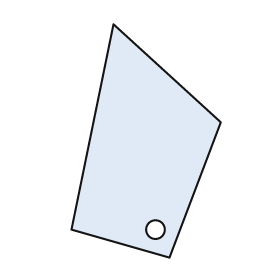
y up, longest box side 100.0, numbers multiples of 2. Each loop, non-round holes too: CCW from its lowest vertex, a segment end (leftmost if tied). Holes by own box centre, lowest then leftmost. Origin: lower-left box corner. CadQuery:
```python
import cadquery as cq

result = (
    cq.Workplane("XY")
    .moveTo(42.0, 0.0)
    .lineTo(64.0, 58.0)
    .lineTo(18.0, 100.0)
    .lineTo(0.0, 12.0)
    .close()
    .moveTo(36.0, 12.0)
    .circle(4.0)
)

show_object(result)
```